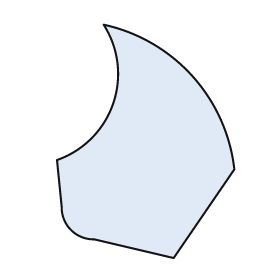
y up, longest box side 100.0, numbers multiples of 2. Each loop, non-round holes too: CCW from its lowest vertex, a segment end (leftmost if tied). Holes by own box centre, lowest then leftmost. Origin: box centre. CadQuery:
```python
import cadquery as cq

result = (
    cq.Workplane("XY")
    .moveTo(12.0, -50.0)
    .lineTo(38.0, -12.0)
    .threePointArc((20.0, 28.0), (-18.0, 50.0))
    .threePointArc((-14.0, 16.0), (-38.0, -8.0))
    .lineTo(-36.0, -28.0)
    .threePointArc((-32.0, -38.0), (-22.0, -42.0))
    .close()
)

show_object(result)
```